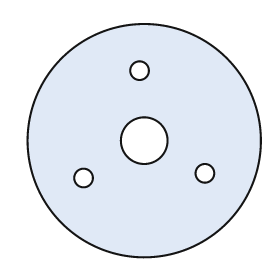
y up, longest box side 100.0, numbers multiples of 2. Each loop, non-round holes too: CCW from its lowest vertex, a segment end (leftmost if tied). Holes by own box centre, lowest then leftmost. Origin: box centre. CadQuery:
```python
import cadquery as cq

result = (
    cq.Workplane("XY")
    .moveTo(0.0, 0.0)
    .circle(50.0)
    .moveTo(-26.0, -16.0)
    .circle(4.0)
    .moveTo(26.0, -14.0)
    .circle(4.0)
    .moveTo(0.0, 0.0)
    .circle(10.0)
    .moveTo(-2.0, 30.0)
    .circle(4.0)
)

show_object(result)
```